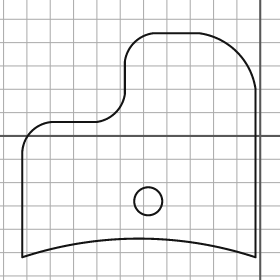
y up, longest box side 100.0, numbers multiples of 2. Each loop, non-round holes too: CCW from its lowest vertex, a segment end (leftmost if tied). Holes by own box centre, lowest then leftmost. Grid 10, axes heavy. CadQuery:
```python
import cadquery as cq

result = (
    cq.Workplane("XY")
    .moveTo(-102.0, -52.0)
    .threePointArc((-52.0, -44.0), (-2.0, -52.0))
    .lineTo(-2.0, 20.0)
    .threePointArc((-10.0, 36.0), (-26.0, 44.0))
    .lineTo(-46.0, 44.0)
    .threePointArc((-54.0, 40.0), (-58.0, 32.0))
    .lineTo(-58.0, 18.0)
    .threePointArc((-62.0, 10.0), (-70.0, 6.0))
    .lineTo(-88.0, 6.0)
    .threePointArc((-98.0, 2.0), (-102.0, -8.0))
    .close()
    .moveTo(-48.0, -28.0)
    .circle(6.0)
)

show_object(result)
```